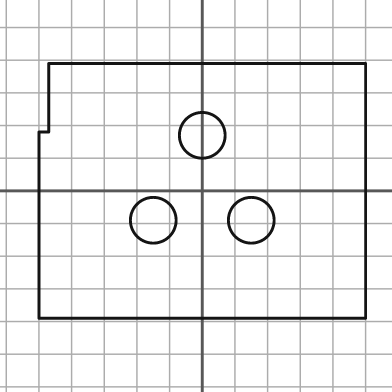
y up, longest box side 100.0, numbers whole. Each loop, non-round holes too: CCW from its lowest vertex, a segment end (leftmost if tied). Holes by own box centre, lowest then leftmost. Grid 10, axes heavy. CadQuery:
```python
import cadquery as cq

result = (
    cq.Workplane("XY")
    .moveTo(-50.0, -39.0)
    .lineTo(50.0, -39.0)
    .lineTo(50.0, 39.0)
    .lineTo(-47.0, 39.0)
    .lineTo(-47.0, 18.0)
    .lineTo(-50.0, 18.0)
    .close()
    .moveTo(-15.0, -9.0)
    .circle(7.0)
    .moveTo(15.0, -9.0)
    .circle(7.0)
    .moveTo(0.0, 17.0)
    .circle(7.0)
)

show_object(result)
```